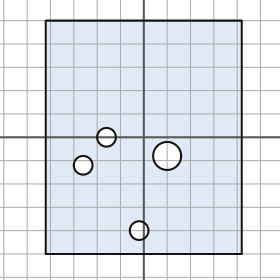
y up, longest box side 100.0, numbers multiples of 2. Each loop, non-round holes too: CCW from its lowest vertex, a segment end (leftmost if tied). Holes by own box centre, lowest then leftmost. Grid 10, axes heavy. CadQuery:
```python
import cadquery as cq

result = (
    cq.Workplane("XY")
    .moveTo(-42.0, -50.0)
    .lineTo(42.0, -50.0)
    .lineTo(42.0, 50.0)
    .lineTo(-42.0, 50.0)
    .close()
    .moveTo(-2.0, -40.0)
    .circle(4.0)
    .moveTo(-26.0, -12.0)
    .circle(4.0)
    .moveTo(10.0, -8.0)
    .circle(6.0)
    .moveTo(-16.0, 0.0)
    .circle(4.0)
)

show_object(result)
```